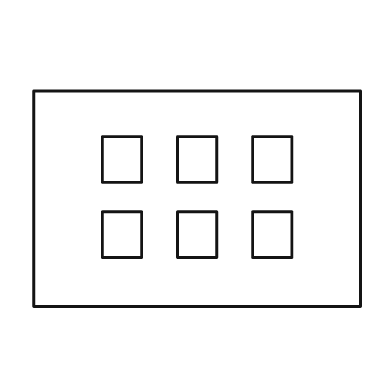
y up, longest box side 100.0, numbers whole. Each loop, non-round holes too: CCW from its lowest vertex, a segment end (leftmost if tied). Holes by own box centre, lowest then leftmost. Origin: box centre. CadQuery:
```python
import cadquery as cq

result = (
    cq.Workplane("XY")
    .moveTo(-50.0, -33.0)
    .lineTo(50.0, -33.0)
    .lineTo(50.0, 33.0)
    .lineTo(-50.0, 33.0)
    .close()
    .moveTo(-29.0, -18.0)
    .lineTo(-17.0, -18.0)
    .lineTo(-17.0, -4.0)
    .lineTo(-29.0, -4.0)
    .close()
    .moveTo(-6.0, -18.0)
    .lineTo(6.0, -18.0)
    .lineTo(6.0, -4.0)
    .lineTo(-6.0, -4.0)
    .close()
    .moveTo(17.0, -18.0)
    .lineTo(29.0, -18.0)
    .lineTo(29.0, -4.0)
    .lineTo(17.0, -4.0)
    .close()
    .moveTo(-29.0, 5.0)
    .lineTo(-17.0, 5.0)
    .lineTo(-17.0, 19.0)
    .lineTo(-29.0, 19.0)
    .close()
    .moveTo(-6.0, 5.0)
    .lineTo(6.0, 5.0)
    .lineTo(6.0, 19.0)
    .lineTo(-6.0, 19.0)
    .close()
    .moveTo(17.0, 5.0)
    .lineTo(29.0, 5.0)
    .lineTo(29.0, 19.0)
    .lineTo(17.0, 19.0)
    .close()
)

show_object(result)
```